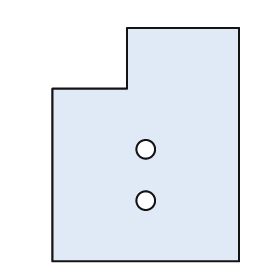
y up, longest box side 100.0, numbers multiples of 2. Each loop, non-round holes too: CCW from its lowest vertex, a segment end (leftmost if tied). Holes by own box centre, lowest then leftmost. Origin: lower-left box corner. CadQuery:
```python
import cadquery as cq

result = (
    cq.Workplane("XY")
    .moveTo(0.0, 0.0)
    .lineTo(80.0, 0.0)
    .lineTo(80.0, 100.0)
    .lineTo(32.0, 100.0)
    .lineTo(32.0, 74.0)
    .lineTo(0.0, 74.0)
    .close()
    .moveTo(40.0, 26.0)
    .circle(4.0)
    .moveTo(40.0, 48.0)
    .circle(4.0)
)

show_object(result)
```